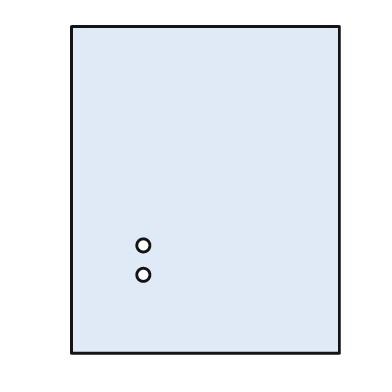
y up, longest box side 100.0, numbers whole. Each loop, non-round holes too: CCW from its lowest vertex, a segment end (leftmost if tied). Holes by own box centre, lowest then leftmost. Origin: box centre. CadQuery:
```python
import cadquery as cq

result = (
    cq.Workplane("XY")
    .moveTo(-41.0, -50.0)
    .lineTo(41.0, -50.0)
    .lineTo(41.0, 50.0)
    .lineTo(-41.0, 50.0)
    .close()
    .moveTo(-19.0, -26.0)
    .circle(2.0)
    .moveTo(-19.0, -17.0)
    .circle(2.0)
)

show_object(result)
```